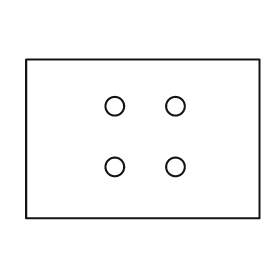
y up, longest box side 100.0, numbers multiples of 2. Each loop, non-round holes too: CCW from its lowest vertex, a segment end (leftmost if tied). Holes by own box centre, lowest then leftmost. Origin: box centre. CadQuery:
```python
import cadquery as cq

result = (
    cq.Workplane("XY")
    .moveTo(-50.0, -34.0)
    .lineTo(50.0, -34.0)
    .lineTo(50.0, 34.0)
    .lineTo(-50.0, 34.0)
    .close()
    .moveTo(-12.0, -12.0)
    .circle(4.0)
    .moveTo(14.0, -12.0)
    .circle(4.0)
    .moveTo(-12.0, 14.0)
    .circle(4.0)
    .moveTo(14.0, 14.0)
    .circle(4.0)
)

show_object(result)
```